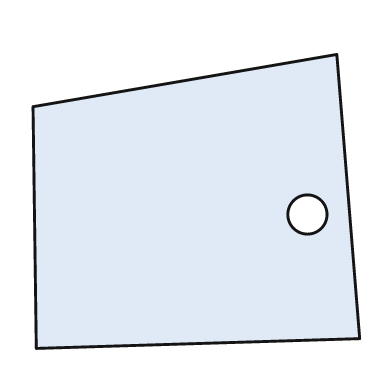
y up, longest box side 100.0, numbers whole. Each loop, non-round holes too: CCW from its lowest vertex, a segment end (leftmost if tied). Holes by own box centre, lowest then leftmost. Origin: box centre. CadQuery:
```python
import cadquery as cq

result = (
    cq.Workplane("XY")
    .moveTo(-49.0, -45.0)
    .lineTo(50.0, -42.0)
    .lineTo(43.0, 45.0)
    .lineTo(-50.0, 29.0)
    .close()
    .moveTo(34.0, -4.0)
    .circle(6.0)
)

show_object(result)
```